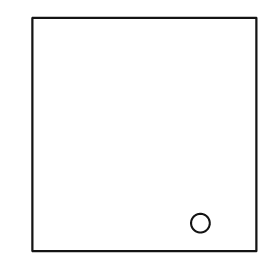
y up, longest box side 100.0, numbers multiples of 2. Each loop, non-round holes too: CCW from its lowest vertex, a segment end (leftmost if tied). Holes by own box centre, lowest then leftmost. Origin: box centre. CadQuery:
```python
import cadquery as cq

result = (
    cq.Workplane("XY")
    .moveTo(-48.0, -50.0)
    .lineTo(48.0, -50.0)
    .lineTo(48.0, 50.0)
    .lineTo(-48.0, 50.0)
    .close()
    .moveTo(24.0, -38.0)
    .circle(4.0)
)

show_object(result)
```